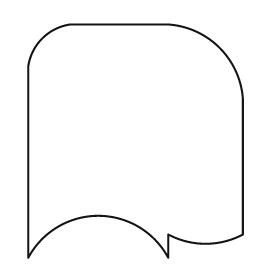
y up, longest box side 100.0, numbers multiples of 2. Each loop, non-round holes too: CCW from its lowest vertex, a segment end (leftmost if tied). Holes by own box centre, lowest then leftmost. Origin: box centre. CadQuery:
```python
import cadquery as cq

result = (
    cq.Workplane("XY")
    .moveTo(-46.0, -50.0)
    .threePointArc((-16.0, -32.0), (14.0, -50.0))
    .lineTo(14.0, -40.0)
    .threePointArc((30.0, -44.0), (46.0, -40.0))
    .lineTo(46.0, 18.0)
    .threePointArc((36.0, 40.0), (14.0, 50.0))
    .lineTo(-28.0, 50.0)
    .threePointArc((-40.0, 44.0), (-46.0, 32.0))
    .close()
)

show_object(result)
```